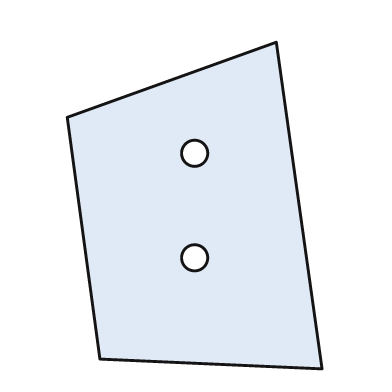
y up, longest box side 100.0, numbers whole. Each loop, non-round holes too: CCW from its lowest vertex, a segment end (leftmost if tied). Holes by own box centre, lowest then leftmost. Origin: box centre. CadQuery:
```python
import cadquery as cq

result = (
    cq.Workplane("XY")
    .moveTo(39.0, -50.0)
    .lineTo(25.0, 50.0)
    .lineTo(-39.0, 27.0)
    .lineTo(-29.0, -47.0)
    .close()
    .moveTo(0.0, -16.0)
    .circle(4.0)
    .moveTo(0.0, 16.0)
    .circle(4.0)
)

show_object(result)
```